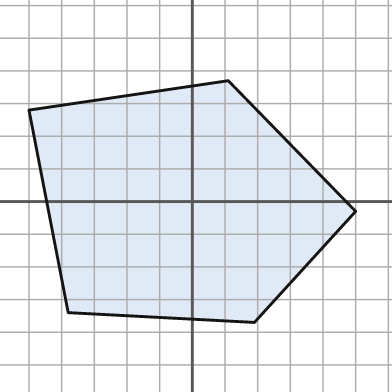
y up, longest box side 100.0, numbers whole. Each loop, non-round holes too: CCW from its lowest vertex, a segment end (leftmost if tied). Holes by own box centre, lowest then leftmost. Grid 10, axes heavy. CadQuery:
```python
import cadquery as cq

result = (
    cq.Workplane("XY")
    .moveTo(19.0, -37.0)
    .lineTo(50.0, -3.0)
    .lineTo(11.0, 37.0)
    .lineTo(-50.0, 28.0)
    .lineTo(-38.0, -34.0)
    .close()
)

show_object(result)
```